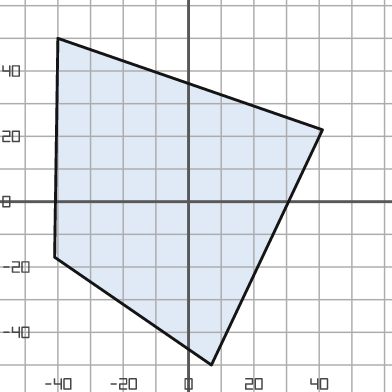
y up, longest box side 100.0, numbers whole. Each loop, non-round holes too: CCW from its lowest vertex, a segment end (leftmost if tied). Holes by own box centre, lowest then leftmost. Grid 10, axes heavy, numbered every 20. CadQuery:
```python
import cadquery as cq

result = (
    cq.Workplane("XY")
    .moveTo(7.0, -50.0)
    .lineTo(41.0, 22.0)
    .lineTo(-40.0, 50.0)
    .lineTo(-41.0, -17.0)
    .close()
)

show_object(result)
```